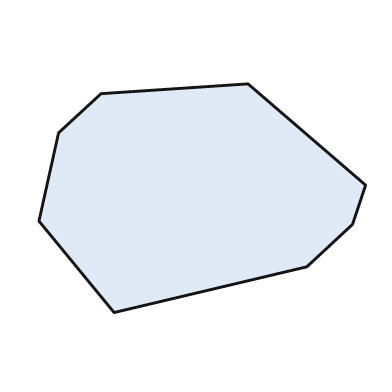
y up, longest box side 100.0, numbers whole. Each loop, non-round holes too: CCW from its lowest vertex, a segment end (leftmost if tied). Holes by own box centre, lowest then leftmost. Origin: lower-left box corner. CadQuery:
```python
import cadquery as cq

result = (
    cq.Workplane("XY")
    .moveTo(23.0, 0.0)
    .lineTo(82.0, 14.0)
    .lineTo(96.0, 27.0)
    .lineTo(100.0, 39.0)
    .lineTo(64.0, 70.0)
    .lineTo(19.0, 67.0)
    .lineTo(6.0, 55.0)
    .lineTo(0.0, 28.0)
    .close()
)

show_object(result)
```